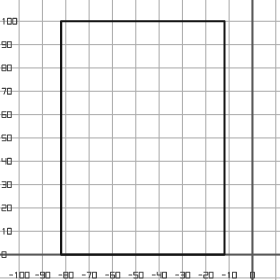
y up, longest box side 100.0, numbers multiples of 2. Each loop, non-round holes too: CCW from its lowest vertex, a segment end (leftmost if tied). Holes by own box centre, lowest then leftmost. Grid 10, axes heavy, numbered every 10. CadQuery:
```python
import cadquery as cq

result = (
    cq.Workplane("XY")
    .moveTo(-82.0, 0.0)
    .lineTo(-12.0, 0.0)
    .lineTo(-12.0, 100.0)
    .lineTo(-82.0, 100.0)
    .close()
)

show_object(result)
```